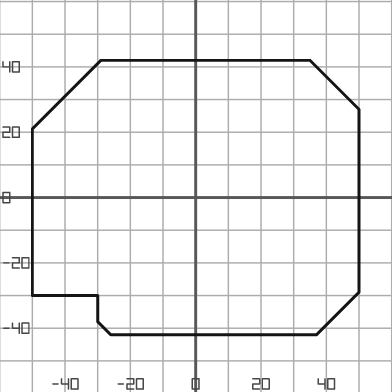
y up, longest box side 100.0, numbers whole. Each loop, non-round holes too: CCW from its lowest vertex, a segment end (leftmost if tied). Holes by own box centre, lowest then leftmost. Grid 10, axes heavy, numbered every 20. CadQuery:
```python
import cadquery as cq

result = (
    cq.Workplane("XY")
    .moveTo(-26.0, -42.0)
    .lineTo(37.0, -42.0)
    .lineTo(50.0, -29.0)
    .lineTo(50.0, 27.0)
    .lineTo(35.0, 42.0)
    .lineTo(-29.0, 42.0)
    .lineTo(-50.0, 21.0)
    .lineTo(-50.0, -30.0)
    .lineTo(-30.0, -30.0)
    .lineTo(-30.0, -38.0)
    .close()
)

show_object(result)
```